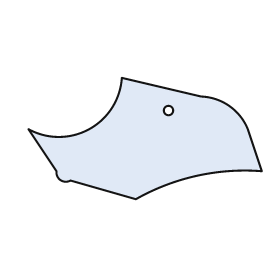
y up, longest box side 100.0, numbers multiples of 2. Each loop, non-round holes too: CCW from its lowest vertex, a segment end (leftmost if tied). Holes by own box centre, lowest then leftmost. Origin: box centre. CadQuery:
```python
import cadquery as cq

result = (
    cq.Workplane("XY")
    .moveTo(-4.0, -26.0)
    .threePointArc((22.0, -16.0), (50.0, -14.0))
    .lineTo(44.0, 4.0)
    .threePointArc((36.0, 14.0), (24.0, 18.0))
    .lineTo(-10.0, 26.0)
    .threePointArc((-24.0, 4.0), (-50.0, 4.0))
    .lineTo(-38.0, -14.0)
    .threePointArc((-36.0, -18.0), (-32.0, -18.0))
    .close()
    .moveTo(10.0, 12.0)
    .circle(2.0)
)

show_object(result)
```